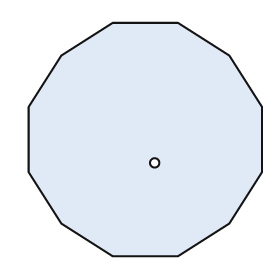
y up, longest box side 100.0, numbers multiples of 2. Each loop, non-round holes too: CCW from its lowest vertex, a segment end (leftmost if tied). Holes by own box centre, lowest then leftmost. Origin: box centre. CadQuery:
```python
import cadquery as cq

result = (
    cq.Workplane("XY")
    .moveTo(-14.0, -50.0)
    .lineTo(14.0, -50.0)
    .lineTo(36.0, -36.0)
    .lineTo(50.0, -14.0)
    .lineTo(50.0, 14.0)
    .lineTo(36.0, 36.0)
    .lineTo(14.0, 50.0)
    .lineTo(-14.0, 50.0)
    .lineTo(-36.0, 36.0)
    .lineTo(-50.0, 14.0)
    .lineTo(-50.0, -14.0)
    .lineTo(-36.0, -36.0)
    .close()
    .moveTo(4.0, -10.0)
    .circle(2.0)
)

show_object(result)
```